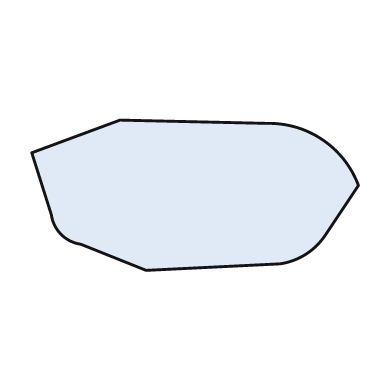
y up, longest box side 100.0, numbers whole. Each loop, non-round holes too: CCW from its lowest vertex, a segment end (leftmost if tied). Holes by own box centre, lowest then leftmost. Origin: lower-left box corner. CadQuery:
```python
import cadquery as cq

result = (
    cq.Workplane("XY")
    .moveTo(35.0, 0.0)
    .lineTo(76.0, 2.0)
    .threePointArc((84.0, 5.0), (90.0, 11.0))
    .lineTo(100.0, 26.0)
    .threePointArc((89.0, 40.0), (72.0, 45.0))
    .lineTo(27.0, 46.0)
    .lineTo(0.0, 36.0)
    .lineTo(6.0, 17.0)
    .threePointArc((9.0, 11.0), (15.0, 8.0))
    .close()
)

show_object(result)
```